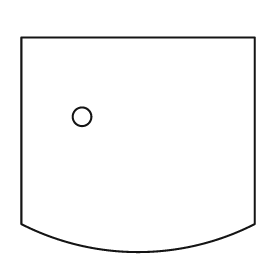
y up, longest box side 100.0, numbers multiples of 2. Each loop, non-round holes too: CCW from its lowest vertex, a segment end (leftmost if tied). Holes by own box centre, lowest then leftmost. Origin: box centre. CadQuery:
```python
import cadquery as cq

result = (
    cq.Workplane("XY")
    .moveTo(-50.0, -34.0)
    .threePointArc((0.0, -46.0), (50.0, -34.0))
    .lineTo(50.0, 46.0)
    .lineTo(-50.0, 46.0)
    .close()
    .moveTo(-24.0, 12.0)
    .circle(4.0)
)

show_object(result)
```